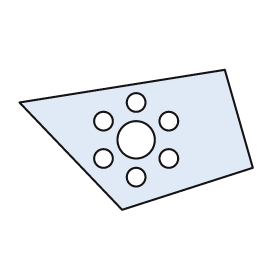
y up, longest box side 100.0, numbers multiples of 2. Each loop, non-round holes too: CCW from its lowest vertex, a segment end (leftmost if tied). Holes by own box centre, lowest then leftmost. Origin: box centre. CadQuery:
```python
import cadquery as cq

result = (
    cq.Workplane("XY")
    .moveTo(-6.0, -30.0)
    .lineTo(50.0, -12.0)
    .lineTo(38.0, 30.0)
    .lineTo(-50.0, 16.0)
    .close()
    .moveTo(0.0, -16.0)
    .circle(4.0)
    .moveTo(-14.0, -8.0)
    .circle(4.0)
    .moveTo(14.0, -8.0)
    .circle(4.0)
    .moveTo(0.0, 0.0)
    .circle(8.0)
    .moveTo(-14.0, 8.0)
    .circle(4.0)
    .moveTo(14.0, 8.0)
    .circle(4.0)
    .moveTo(0.0, 16.0)
    .circle(4.0)
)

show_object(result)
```